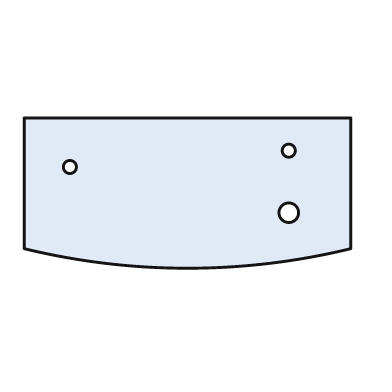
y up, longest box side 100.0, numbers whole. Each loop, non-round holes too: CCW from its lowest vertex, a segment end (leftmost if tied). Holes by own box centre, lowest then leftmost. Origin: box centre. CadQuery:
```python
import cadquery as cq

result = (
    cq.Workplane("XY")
    .moveTo(-50.0, -17.0)
    .threePointArc((0.0, -23.0), (50.0, -17.0))
    .lineTo(50.0, 23.0)
    .lineTo(-50.0, 23.0)
    .close()
    .moveTo(31.0, -6.0)
    .circle(3.0)
    .moveTo(-36.0, 8.0)
    .circle(2.0)
    .moveTo(31.0, 13.0)
    .circle(2.0)
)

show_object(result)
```